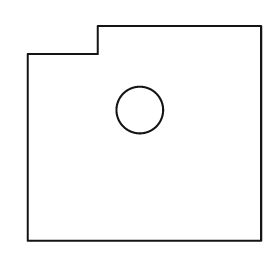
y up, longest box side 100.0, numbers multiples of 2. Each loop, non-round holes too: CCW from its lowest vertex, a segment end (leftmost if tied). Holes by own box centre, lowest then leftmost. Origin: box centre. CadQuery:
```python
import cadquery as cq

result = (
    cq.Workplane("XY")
    .moveTo(-50.0, -46.0)
    .lineTo(50.0, -46.0)
    .lineTo(50.0, 46.0)
    .lineTo(-20.0, 46.0)
    .lineTo(-20.0, 34.0)
    .lineTo(-50.0, 34.0)
    .close()
    .moveTo(-2.0, 10.0)
    .circle(10.0)
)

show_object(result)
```